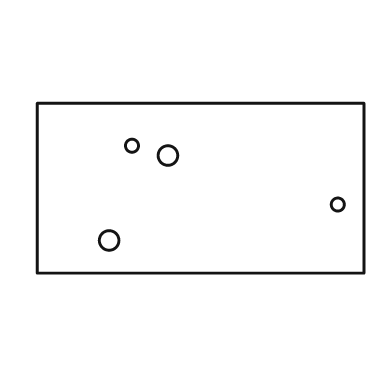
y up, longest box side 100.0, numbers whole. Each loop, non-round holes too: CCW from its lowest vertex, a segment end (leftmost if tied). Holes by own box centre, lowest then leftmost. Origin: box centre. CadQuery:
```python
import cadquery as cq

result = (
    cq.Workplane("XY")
    .moveTo(-50.0, -26.0)
    .lineTo(50.0, -26.0)
    .lineTo(50.0, 26.0)
    .lineTo(-50.0, 26.0)
    .close()
    .moveTo(-28.0, -16.0)
    .circle(3.0)
    .moveTo(42.0, -5.0)
    .circle(2.0)
    .moveTo(-10.0, 10.0)
    .circle(3.0)
    .moveTo(-21.0, 13.0)
    .circle(2.0)
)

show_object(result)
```